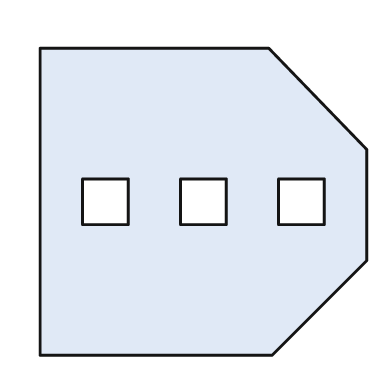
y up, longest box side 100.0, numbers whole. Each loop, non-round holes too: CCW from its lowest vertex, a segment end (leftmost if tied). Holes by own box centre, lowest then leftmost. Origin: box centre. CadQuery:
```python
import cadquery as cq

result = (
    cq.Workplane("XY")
    .moveTo(-50.0, -47.0)
    .lineTo(21.0, -47.0)
    .lineTo(50.0, -18.0)
    .lineTo(50.0, 16.0)
    .lineTo(20.0, 47.0)
    .lineTo(-50.0, 47.0)
    .close()
    .moveTo(-37.0, -7.0)
    .lineTo(-23.0, -7.0)
    .lineTo(-23.0, 7.0)
    .lineTo(-37.0, 7.0)
    .close()
    .moveTo(-7.0, -7.0)
    .lineTo(7.0, -7.0)
    .lineTo(7.0, 7.0)
    .lineTo(-7.0, 7.0)
    .close()
    .moveTo(23.0, -7.0)
    .lineTo(37.0, -7.0)
    .lineTo(37.0, 7.0)
    .lineTo(23.0, 7.0)
    .close()
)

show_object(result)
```